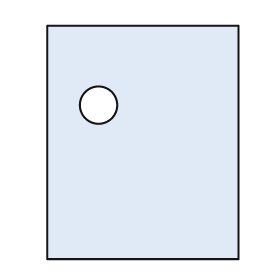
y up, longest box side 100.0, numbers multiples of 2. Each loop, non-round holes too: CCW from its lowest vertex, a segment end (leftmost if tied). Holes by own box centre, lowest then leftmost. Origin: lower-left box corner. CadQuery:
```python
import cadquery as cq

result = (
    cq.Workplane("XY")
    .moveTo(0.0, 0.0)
    .lineTo(82.0, 0.0)
    .lineTo(82.0, 100.0)
    .lineTo(0.0, 100.0)
    .close()
    .moveTo(22.0, 66.0)
    .circle(8.0)
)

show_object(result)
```